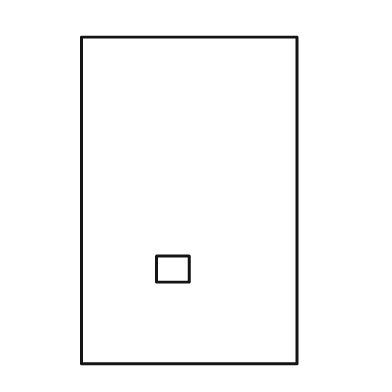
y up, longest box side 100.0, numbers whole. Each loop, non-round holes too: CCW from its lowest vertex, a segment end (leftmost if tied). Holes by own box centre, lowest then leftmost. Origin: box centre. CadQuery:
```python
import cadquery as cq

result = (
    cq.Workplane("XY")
    .moveTo(-33.0, -50.0)
    .lineTo(33.0, -50.0)
    .lineTo(33.0, 50.0)
    .lineTo(-33.0, 50.0)
    .close()
    .moveTo(-10.0, -25.0)
    .lineTo(0.0, -25.0)
    .lineTo(0.0, -17.0)
    .lineTo(-10.0, -17.0)
    .close()
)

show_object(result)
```